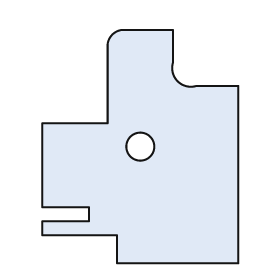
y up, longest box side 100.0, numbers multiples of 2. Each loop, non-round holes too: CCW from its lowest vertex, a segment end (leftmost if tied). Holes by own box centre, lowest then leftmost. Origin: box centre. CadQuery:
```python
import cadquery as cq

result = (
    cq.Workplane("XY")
    .moveTo(-10.0, -50.0)
    .lineTo(42.0, -50.0)
    .lineTo(42.0, 26.0)
    .lineTo(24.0, 26.0)
    .threePointArc((16.0, 28.0), (14.0, 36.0))
    .lineTo(14.0, 50.0)
    .lineTo(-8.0, 50.0)
    .threePointArc((-12.0, 48.0), (-14.0, 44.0))
    .lineTo(-14.0, 10.0)
    .lineTo(-42.0, 10.0)
    .lineTo(-42.0, -26.0)
    .lineTo(-22.0, -26.0)
    .lineTo(-22.0, -32.0)
    .lineTo(-42.0, -32.0)
    .lineTo(-42.0, -38.0)
    .lineTo(-10.0, -38.0)
    .close()
    .moveTo(0.0, 0.0)
    .circle(6.0)
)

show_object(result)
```